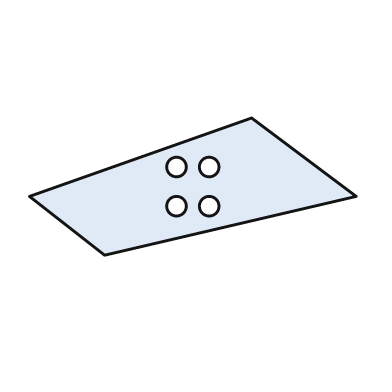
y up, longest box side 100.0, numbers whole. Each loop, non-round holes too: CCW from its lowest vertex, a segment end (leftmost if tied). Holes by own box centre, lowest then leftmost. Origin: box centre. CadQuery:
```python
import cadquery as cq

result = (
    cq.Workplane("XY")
    .moveTo(-27.0, -21.0)
    .lineTo(50.0, -3.0)
    .lineTo(18.0, 21.0)
    .lineTo(-50.0, -3.0)
    .close()
    .moveTo(-5.0, -6.0)
    .circle(3.0)
    .moveTo(5.0, -6.0)
    .circle(3.0)
    .moveTo(-5.0, 6.0)
    .circle(3.0)
    .moveTo(5.0, 6.0)
    .circle(3.0)
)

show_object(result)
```